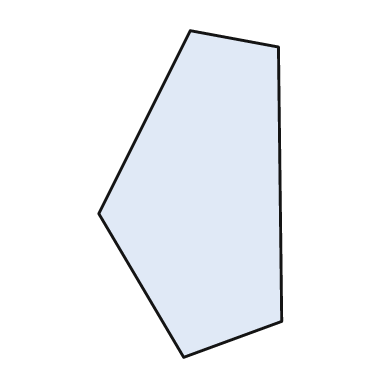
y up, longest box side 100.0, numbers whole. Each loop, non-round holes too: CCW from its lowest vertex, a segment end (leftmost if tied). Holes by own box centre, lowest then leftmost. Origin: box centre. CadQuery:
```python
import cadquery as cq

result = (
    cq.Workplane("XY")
    .moveTo(-2.0, -50.0)
    .lineTo(28.0, -39.0)
    .lineTo(27.0, 45.0)
    .lineTo(0.0, 50.0)
    .lineTo(-28.0, -6.0)
    .close()
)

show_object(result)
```